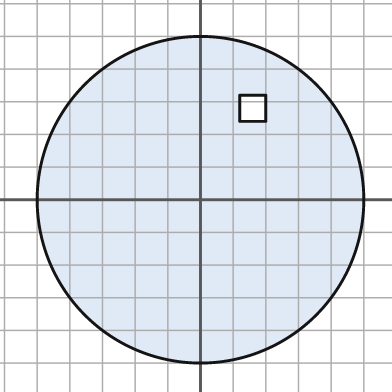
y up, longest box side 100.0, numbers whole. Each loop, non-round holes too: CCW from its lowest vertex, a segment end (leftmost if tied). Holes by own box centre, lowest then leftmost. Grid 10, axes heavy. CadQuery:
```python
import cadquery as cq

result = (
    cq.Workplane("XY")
    .moveTo(0.0, 0.0)
    .circle(50.0)
    .moveTo(12.0, 24.0)
    .lineTo(20.0, 24.0)
    .lineTo(20.0, 32.0)
    .lineTo(12.0, 32.0)
    .close()
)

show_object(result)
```